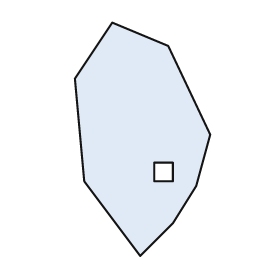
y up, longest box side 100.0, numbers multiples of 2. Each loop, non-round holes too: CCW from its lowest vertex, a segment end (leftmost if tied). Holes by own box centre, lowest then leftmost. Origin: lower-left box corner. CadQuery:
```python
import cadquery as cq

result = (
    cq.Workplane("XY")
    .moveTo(28.0, 0.0)
    .lineTo(42.0, 14.0)
    .lineTo(52.0, 30.0)
    .lineTo(58.0, 52.0)
    .lineTo(40.0, 90.0)
    .lineTo(16.0, 100.0)
    .lineTo(0.0, 76.0)
    .lineTo(4.0, 32.0)
    .close()
    .moveTo(34.0, 32.0)
    .lineTo(42.0, 32.0)
    .lineTo(42.0, 40.0)
    .lineTo(34.0, 40.0)
    .close()
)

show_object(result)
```